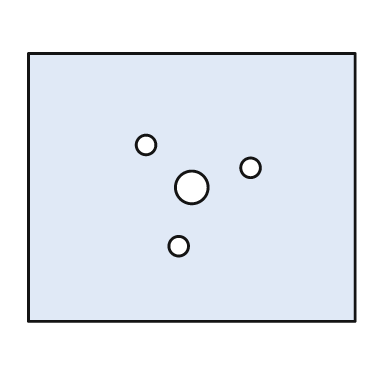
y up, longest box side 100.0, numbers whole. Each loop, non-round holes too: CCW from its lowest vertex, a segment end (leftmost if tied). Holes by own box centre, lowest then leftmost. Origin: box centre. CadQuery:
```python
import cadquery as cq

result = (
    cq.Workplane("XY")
    .moveTo(-50.0, -41.0)
    .lineTo(50.0, -41.0)
    .lineTo(50.0, 41.0)
    .lineTo(-50.0, 41.0)
    .close()
    .moveTo(-4.0, -18.0)
    .circle(3.0)
    .moveTo(0.0, 0.0)
    .circle(5.0)
    .moveTo(18.0, 6.0)
    .circle(3.0)
    .moveTo(-14.0, 13.0)
    .circle(3.0)
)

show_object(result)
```